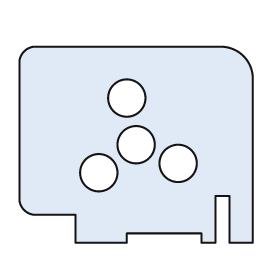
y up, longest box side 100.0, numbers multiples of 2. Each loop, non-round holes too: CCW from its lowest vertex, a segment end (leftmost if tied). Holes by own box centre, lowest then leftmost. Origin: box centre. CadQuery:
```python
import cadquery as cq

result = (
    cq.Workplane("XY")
    .moveTo(-26.0, -42.0)
    .lineTo(-4.0, -42.0)
    .lineTo(-4.0, -38.0)
    .lineTo(28.0, -38.0)
    .lineTo(28.0, -42.0)
    .lineTo(34.0, -42.0)
    .lineTo(34.0, -22.0)
    .lineTo(40.0, -22.0)
    .lineTo(40.0, -42.0)
    .lineTo(50.0, -42.0)
    .lineTo(50.0, 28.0)
    .threePointArc((46.0, 38.0), (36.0, 42.0))
    .lineTo(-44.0, 42.0)
    .threePointArc((-48.0, 40.0), (-50.0, 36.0))
    .lineTo(-50.0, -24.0)
    .threePointArc((-48.0, -28.0), (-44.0, -30.0))
    .lineTo(-26.0, -30.0)
    .close()
    .moveTo(-16.0, -12.0)
    .circle(8.0)
    .moveTo(18.0, -8.0)
    .circle(8.0)
    .moveTo(0.0, 0.0)
    .circle(8.0)
    .moveTo(-4.0, 20.0)
    .circle(8.0)
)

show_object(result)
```